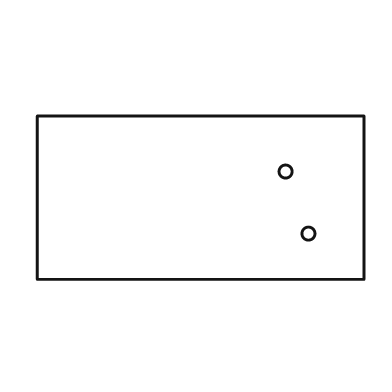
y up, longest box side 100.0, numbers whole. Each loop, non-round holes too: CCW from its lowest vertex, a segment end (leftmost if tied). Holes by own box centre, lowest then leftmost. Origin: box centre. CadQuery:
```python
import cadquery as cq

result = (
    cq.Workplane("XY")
    .moveTo(-50.0, -25.0)
    .lineTo(50.0, -25.0)
    .lineTo(50.0, 25.0)
    .lineTo(-50.0, 25.0)
    .close()
    .moveTo(33.0, -11.0)
    .circle(2.0)
    .moveTo(26.0, 8.0)
    .circle(2.0)
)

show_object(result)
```